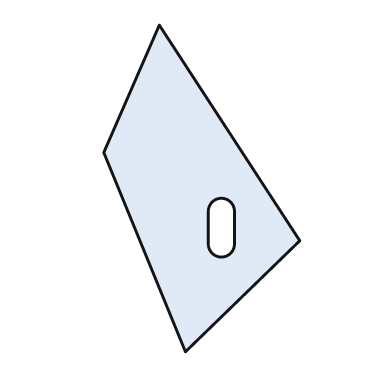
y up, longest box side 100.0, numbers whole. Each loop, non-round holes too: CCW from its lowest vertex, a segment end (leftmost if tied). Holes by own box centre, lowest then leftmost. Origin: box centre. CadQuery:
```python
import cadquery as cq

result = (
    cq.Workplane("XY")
    .moveTo(-5.0, -50.0)
    .lineTo(30.0, -16.0)
    .lineTo(-13.0, 50.0)
    .lineTo(-30.0, 11.0)
    .close()
    .moveTo(2.0, -17.0)
    .threePointArc((6.0, -21.0), (10.0, -17.0))
    .lineTo(10.0, -7.0)
    .threePointArc((6.0, -3.0), (2.0, -7.0))
    .close()
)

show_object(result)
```